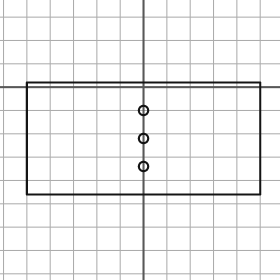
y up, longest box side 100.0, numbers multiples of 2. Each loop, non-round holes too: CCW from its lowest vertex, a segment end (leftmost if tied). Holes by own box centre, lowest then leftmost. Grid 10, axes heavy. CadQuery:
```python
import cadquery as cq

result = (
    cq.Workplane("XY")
    .moveTo(-50.0, -46.0)
    .lineTo(50.0, -46.0)
    .lineTo(50.0, 2.0)
    .lineTo(-50.0, 2.0)
    .close()
    .moveTo(0.0, -34.0)
    .circle(2.0)
    .moveTo(0.0, -22.0)
    .circle(2.0)
    .moveTo(0.0, -10.0)
    .circle(2.0)
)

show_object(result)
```